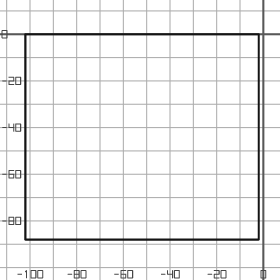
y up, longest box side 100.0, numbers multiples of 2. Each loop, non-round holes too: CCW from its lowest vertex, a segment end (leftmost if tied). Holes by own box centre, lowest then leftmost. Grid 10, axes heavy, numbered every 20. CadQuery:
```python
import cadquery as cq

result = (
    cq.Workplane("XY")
    .moveTo(-102.0, -88.0)
    .lineTo(-2.0, -88.0)
    .lineTo(-2.0, 0.0)
    .lineTo(-102.0, 0.0)
    .close()
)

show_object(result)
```